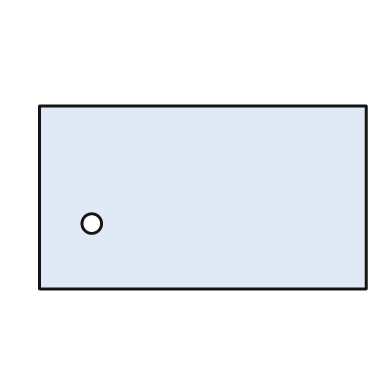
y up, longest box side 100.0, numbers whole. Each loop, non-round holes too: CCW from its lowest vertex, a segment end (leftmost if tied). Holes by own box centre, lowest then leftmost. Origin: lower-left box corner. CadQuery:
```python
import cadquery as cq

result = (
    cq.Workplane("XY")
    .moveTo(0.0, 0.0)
    .lineTo(100.0, 0.0)
    .lineTo(100.0, 56.0)
    .lineTo(0.0, 56.0)
    .close()
    .moveTo(16.0, 20.0)
    .circle(3.0)
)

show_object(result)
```